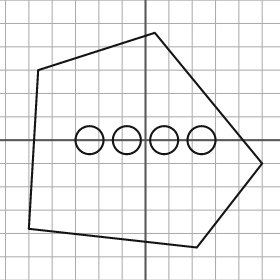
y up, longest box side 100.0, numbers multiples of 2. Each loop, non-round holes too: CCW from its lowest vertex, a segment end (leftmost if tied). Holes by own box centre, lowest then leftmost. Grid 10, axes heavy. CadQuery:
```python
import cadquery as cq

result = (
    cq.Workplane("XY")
    .moveTo(22.0, -46.0)
    .lineTo(50.0, -10.0)
    .lineTo(4.0, 46.0)
    .lineTo(-46.0, 30.0)
    .lineTo(-50.0, -38.0)
    .close()
    .moveTo(-24.0, 0.0)
    .circle(6.0)
    .moveTo(-8.0, 0.0)
    .circle(6.0)
    .moveTo(8.0, 0.0)
    .circle(6.0)
    .moveTo(24.0, 0.0)
    .circle(6.0)
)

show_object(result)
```